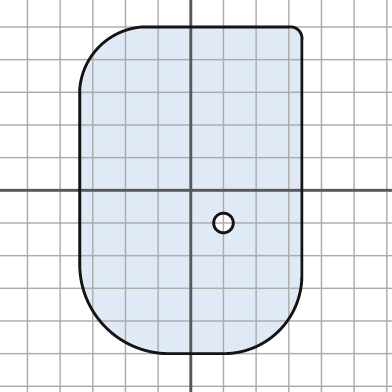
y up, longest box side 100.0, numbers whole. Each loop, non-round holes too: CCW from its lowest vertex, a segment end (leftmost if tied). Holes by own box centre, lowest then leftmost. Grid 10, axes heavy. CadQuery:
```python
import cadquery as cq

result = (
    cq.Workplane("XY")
    .moveTo(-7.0, -50.0)
    .lineTo(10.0, -50.0)
    .threePointArc((27.0, -43.0), (34.0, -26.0))
    .lineTo(34.0, 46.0)
    .threePointArc((33.0, 49.0), (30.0, 50.0))
    .lineTo(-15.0, 50.0)
    .threePointArc((-28.0, 44.0), (-34.0, 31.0))
    .lineTo(-34.0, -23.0)
    .threePointArc((-26.0, -42.0), (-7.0, -50.0))
    .close()
    .moveTo(10.0, -10.0)
    .circle(3.0)
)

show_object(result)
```